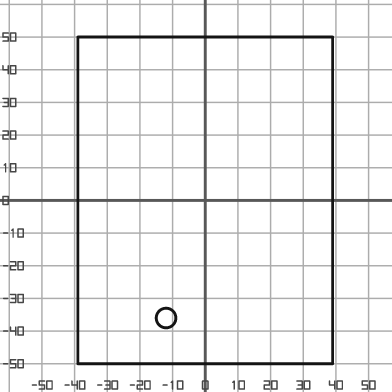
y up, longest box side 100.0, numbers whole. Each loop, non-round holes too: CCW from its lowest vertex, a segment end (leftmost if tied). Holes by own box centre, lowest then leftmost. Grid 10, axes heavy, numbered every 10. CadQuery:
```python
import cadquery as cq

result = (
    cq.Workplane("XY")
    .moveTo(-39.0, -50.0)
    .lineTo(39.0, -50.0)
    .lineTo(39.0, 50.0)
    .lineTo(-39.0, 50.0)
    .close()
    .moveTo(-12.0, -36.0)
    .circle(3.0)
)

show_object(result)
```